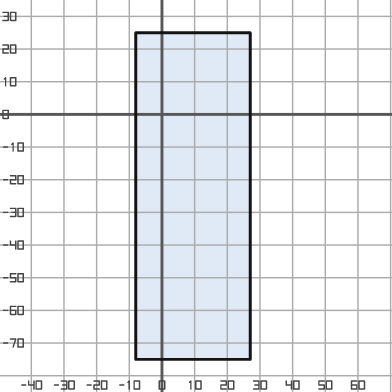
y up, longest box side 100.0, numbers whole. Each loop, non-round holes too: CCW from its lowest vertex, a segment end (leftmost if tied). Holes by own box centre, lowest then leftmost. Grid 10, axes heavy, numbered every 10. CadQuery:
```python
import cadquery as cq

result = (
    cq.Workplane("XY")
    .moveTo(-8.0, -75.0)
    .lineTo(27.0, -75.0)
    .lineTo(27.0, 25.0)
    .lineTo(-8.0, 25.0)
    .close()
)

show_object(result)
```